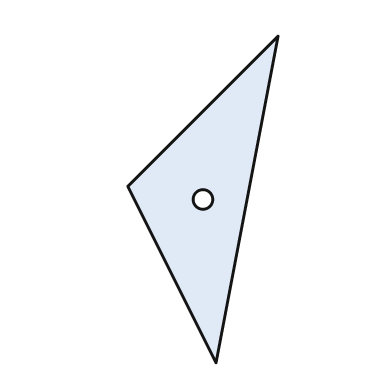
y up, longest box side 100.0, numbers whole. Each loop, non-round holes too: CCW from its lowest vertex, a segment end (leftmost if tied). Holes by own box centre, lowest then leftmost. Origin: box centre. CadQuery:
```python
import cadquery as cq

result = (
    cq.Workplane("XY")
    .moveTo(4.0, -50.0)
    .lineTo(23.0, 50.0)
    .lineTo(-23.0, 4.0)
    .close()
    .moveTo(0.0, 0.0)
    .circle(3.0)
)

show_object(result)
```